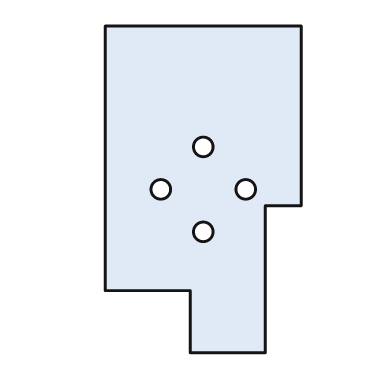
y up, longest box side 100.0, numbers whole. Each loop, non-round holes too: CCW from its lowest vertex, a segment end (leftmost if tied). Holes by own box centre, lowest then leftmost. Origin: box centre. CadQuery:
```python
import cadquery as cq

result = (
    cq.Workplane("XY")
    .moveTo(-4.0, -50.0)
    .lineTo(19.0, -50.0)
    .lineTo(19.0, -5.0)
    .lineTo(30.0, -5.0)
    .lineTo(30.0, 50.0)
    .lineTo(-30.0, 50.0)
    .lineTo(-30.0, -31.0)
    .lineTo(-4.0, -31.0)
    .close()
    .moveTo(0.0, -13.0)
    .circle(3.0)
    .moveTo(-13.0, 0.0)
    .circle(3.0)
    .moveTo(13.0, 0.0)
    .circle(3.0)
    .moveTo(0.0, 13.0)
    .circle(3.0)
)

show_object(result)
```